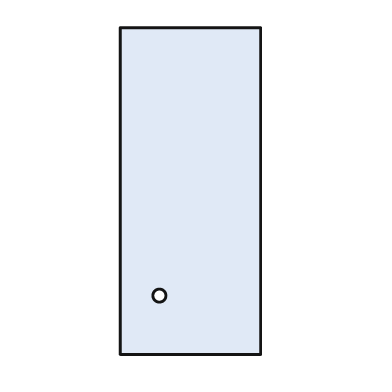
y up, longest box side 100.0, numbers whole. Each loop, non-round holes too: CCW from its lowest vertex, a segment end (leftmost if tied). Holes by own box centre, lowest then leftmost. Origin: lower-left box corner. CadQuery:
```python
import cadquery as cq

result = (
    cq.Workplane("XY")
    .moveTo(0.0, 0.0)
    .lineTo(43.0, 0.0)
    .lineTo(43.0, 100.0)
    .lineTo(0.0, 100.0)
    .close()
    .moveTo(12.0, 18.0)
    .circle(2.0)
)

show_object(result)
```